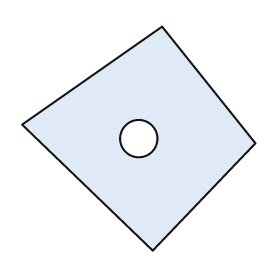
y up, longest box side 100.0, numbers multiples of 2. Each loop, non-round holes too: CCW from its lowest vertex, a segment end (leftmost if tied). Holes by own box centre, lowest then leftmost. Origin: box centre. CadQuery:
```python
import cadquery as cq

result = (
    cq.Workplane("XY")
    .moveTo(6.0, -48.0)
    .lineTo(50.0, -2.0)
    .lineTo(10.0, 48.0)
    .lineTo(-50.0, 6.0)
    .close()
    .moveTo(0.0, 0.0)
    .circle(8.0)
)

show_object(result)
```